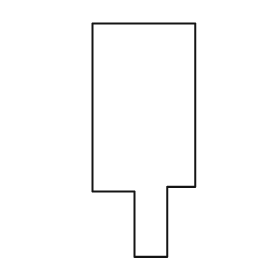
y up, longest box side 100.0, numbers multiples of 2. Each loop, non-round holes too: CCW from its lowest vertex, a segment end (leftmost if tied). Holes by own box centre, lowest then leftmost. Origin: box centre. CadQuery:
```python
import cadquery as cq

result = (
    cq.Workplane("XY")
    .moveTo(-4.0, -50.0)
    .lineTo(10.0, -50.0)
    .lineTo(10.0, -20.0)
    .lineTo(22.0, -20.0)
    .lineTo(22.0, 50.0)
    .lineTo(-22.0, 50.0)
    .lineTo(-22.0, -22.0)
    .lineTo(-4.0, -22.0)
    .close()
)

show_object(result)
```